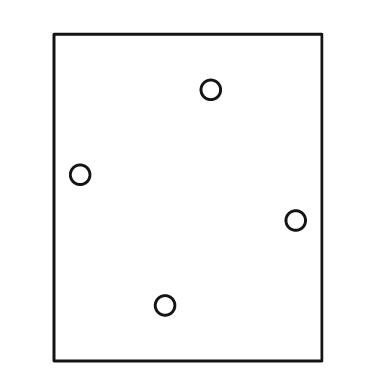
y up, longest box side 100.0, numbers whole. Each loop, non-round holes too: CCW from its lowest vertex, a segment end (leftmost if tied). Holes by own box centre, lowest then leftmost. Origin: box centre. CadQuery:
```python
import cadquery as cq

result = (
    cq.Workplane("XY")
    .moveTo(-41.0, -50.0)
    .lineTo(41.0, -50.0)
    .lineTo(41.0, 50.0)
    .lineTo(-41.0, 50.0)
    .close()
    .moveTo(-7.0, -33.0)
    .circle(3.0)
    .moveTo(33.0, -7.0)
    .circle(3.0)
    .moveTo(-33.0, 7.0)
    .circle(3.0)
    .moveTo(7.0, 33.0)
    .circle(3.0)
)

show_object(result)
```